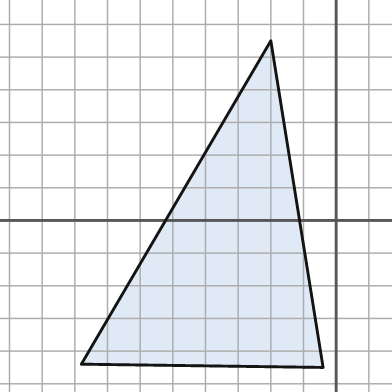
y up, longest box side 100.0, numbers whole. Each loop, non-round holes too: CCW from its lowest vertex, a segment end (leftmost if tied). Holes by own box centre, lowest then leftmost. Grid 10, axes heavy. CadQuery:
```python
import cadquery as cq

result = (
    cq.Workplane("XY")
    .moveTo(-4.0, -45.0)
    .lineTo(-20.0, 55.0)
    .lineTo(-78.0, -44.0)
    .close()
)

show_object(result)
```